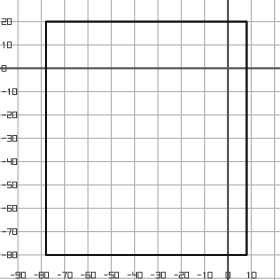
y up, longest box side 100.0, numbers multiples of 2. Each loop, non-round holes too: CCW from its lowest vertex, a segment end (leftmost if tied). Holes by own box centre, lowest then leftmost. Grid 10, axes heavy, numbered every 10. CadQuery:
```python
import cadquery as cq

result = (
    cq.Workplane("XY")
    .moveTo(-78.0, -80.0)
    .lineTo(8.0, -80.0)
    .lineTo(8.0, 20.0)
    .lineTo(-78.0, 20.0)
    .close()
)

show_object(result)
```